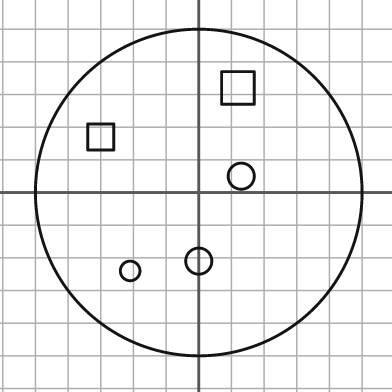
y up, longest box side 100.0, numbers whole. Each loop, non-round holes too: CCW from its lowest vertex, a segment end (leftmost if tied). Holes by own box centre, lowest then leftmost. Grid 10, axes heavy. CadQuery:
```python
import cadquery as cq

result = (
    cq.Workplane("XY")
    .moveTo(0.0, 0.0)
    .circle(50.0)
    .moveTo(-21.0, -24.0)
    .circle(3.0)
    .moveTo(0.0, -21.0)
    .circle(4.0)
    .moveTo(13.0, 5.0)
    .circle(4.0)
    .moveTo(-34.0, 13.0)
    .lineTo(-26.0, 13.0)
    .lineTo(-26.0, 21.0)
    .lineTo(-34.0, 21.0)
    .close()
    .moveTo(7.0, 27.0)
    .lineTo(17.0, 27.0)
    .lineTo(17.0, 37.0)
    .lineTo(7.0, 37.0)
    .close()
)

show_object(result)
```